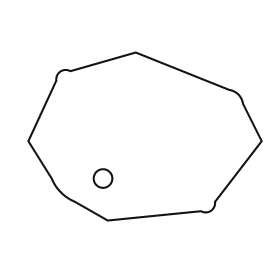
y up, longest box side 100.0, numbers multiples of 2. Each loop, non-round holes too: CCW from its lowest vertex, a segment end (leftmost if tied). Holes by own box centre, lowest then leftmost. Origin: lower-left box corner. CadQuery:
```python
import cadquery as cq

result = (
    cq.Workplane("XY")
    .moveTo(34.0, 0.0)
    .lineTo(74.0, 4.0)
    .threePointArc((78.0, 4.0), (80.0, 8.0))
    .lineTo(100.0, 34.0)
    .lineTo(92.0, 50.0)
    .threePointArc((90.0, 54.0), (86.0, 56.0))
    .lineTo(46.0, 72.0)
    .lineTo(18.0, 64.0)
    .threePointArc((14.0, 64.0), (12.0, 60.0))
    .lineTo(0.0, 34.0)
    .lineTo(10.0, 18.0)
    .threePointArc((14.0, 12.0), (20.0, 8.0))
    .close()
    .moveTo(32.0, 18.0)
    .circle(4.0)
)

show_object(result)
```